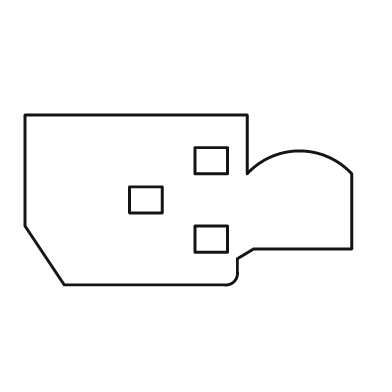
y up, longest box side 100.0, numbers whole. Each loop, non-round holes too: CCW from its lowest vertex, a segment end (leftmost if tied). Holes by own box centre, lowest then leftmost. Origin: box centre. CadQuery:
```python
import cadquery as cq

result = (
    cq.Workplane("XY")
    .moveTo(-38.0, -26.0)
    .lineTo(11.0, -26.0)
    .threePointArc((14.0, -25.0), (15.0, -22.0))
    .lineTo(15.0, -18.0)
    .lineTo(20.0, -15.0)
    .lineTo(50.0, -15.0)
    .lineTo(50.0, 8.0)
    .threePointArc((34.0, 15.0), (18.0, 8.0))
    .lineTo(18.0, 26.0)
    .lineTo(-50.0, 26.0)
    .lineTo(-50.0, -8.0)
    .close()
    .moveTo(2.0, -16.0)
    .lineTo(12.0, -16.0)
    .lineTo(12.0, -8.0)
    .lineTo(2.0, -8.0)
    .close()
    .moveTo(-18.0, -4.0)
    .lineTo(-8.0, -4.0)
    .lineTo(-8.0, 4.0)
    .lineTo(-18.0, 4.0)
    .close()
    .moveTo(2.0, 8.0)
    .lineTo(12.0, 8.0)
    .lineTo(12.0, 16.0)
    .lineTo(2.0, 16.0)
    .close()
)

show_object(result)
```